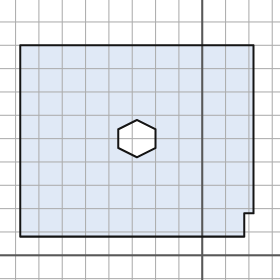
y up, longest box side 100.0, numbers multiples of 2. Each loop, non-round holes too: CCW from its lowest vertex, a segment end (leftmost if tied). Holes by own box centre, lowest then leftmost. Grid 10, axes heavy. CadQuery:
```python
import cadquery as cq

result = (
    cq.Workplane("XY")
    .moveTo(-78.0, 8.0)
    .lineTo(18.0, 8.0)
    .lineTo(18.0, 18.0)
    .lineTo(22.0, 18.0)
    .lineTo(22.0, 90.0)
    .lineTo(-78.0, 90.0)
    .close()
    .moveTo(-28.0, 42.0)
    .lineTo(-20.0, 46.0)
    .lineTo(-20.0, 54.0)
    .lineTo(-28.0, 58.0)
    .lineTo(-36.0, 54.0)
    .lineTo(-36.0, 46.0)
    .close()
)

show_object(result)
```